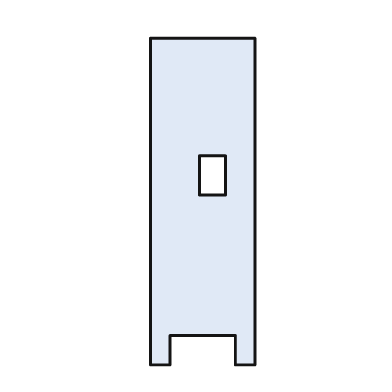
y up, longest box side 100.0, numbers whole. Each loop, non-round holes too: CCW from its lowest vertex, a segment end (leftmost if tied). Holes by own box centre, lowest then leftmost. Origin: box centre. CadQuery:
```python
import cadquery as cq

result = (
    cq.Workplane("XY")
    .moveTo(-16.0, -50.0)
    .lineTo(-10.0, -50.0)
    .lineTo(-10.0, -41.0)
    .lineTo(10.0, -41.0)
    .lineTo(10.0, -50.0)
    .lineTo(16.0, -50.0)
    .lineTo(16.0, 50.0)
    .lineTo(-16.0, 50.0)
    .close()
    .moveTo(-1.0, 2.0)
    .lineTo(7.0, 2.0)
    .lineTo(7.0, 14.0)
    .lineTo(-1.0, 14.0)
    .close()
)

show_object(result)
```